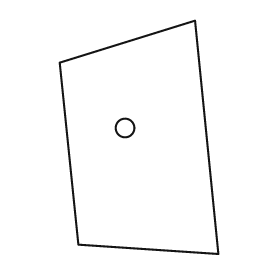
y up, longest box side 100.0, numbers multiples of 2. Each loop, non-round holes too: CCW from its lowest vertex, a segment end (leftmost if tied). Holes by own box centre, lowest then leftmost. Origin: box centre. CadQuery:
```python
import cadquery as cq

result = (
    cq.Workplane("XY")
    .moveTo(34.0, -50.0)
    .lineTo(24.0, 50.0)
    .lineTo(-34.0, 32.0)
    .lineTo(-26.0, -46.0)
    .close()
    .moveTo(-6.0, 4.0)
    .circle(4.0)
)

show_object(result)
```